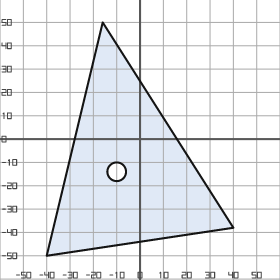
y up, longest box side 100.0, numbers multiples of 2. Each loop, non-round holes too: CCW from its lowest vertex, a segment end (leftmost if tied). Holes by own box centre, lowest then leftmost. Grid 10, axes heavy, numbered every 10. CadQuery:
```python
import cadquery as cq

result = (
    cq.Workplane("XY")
    .moveTo(-40.0, -50.0)
    .lineTo(40.0, -38.0)
    .lineTo(-16.0, 50.0)
    .close()
    .moveTo(-10.0, -14.0)
    .circle(4.0)
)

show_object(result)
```